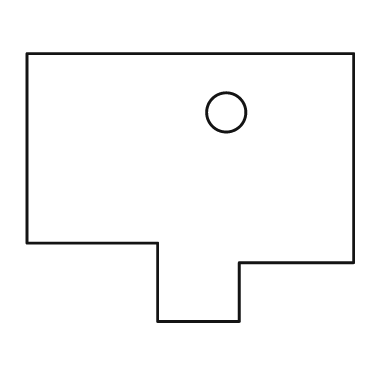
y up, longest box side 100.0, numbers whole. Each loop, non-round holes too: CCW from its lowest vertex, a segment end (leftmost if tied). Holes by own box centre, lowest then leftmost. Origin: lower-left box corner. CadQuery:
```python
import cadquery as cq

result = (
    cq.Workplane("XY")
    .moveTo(40.0, 0.0)
    .lineTo(65.0, 0.0)
    .lineTo(65.0, 18.0)
    .lineTo(100.0, 18.0)
    .lineTo(100.0, 82.0)
    .lineTo(0.0, 82.0)
    .lineTo(0.0, 24.0)
    .lineTo(40.0, 24.0)
    .close()
    .moveTo(61.0, 64.0)
    .circle(6.0)
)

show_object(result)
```